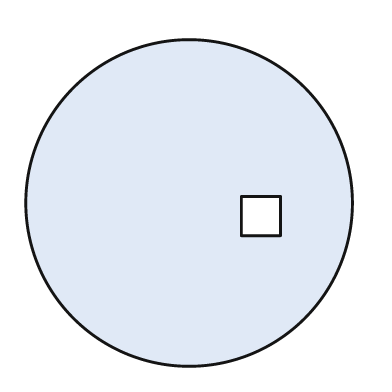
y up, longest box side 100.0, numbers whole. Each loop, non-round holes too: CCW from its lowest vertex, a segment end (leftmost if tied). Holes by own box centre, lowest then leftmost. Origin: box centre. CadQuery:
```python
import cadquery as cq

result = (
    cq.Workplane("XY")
    .moveTo(0.0, 0.0)
    .circle(50.0)
    .moveTo(16.0, -10.0)
    .lineTo(28.0, -10.0)
    .lineTo(28.0, 2.0)
    .lineTo(16.0, 2.0)
    .close()
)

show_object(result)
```